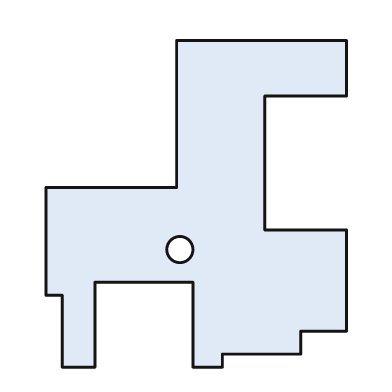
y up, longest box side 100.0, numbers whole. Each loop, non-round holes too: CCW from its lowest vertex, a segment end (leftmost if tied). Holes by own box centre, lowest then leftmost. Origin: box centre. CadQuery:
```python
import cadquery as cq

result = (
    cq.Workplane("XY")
    .moveTo(-41.0, -50.0)
    .lineTo(-31.0, -50.0)
    .lineTo(-31.0, -24.0)
    .lineTo(-1.0, -24.0)
    .lineTo(-1.0, -50.0)
    .lineTo(8.0, -50.0)
    .lineTo(8.0, -46.0)
    .lineTo(32.0, -46.0)
    .lineTo(32.0, -39.0)
    .lineTo(46.0, -39.0)
    .lineTo(46.0, -8.0)
    .lineTo(21.0, -8.0)
    .lineTo(21.0, 33.0)
    .lineTo(46.0, 33.0)
    .lineTo(46.0, 50.0)
    .lineTo(-6.0, 50.0)
    .lineTo(-6.0, 5.0)
    .lineTo(-46.0, 5.0)
    .lineTo(-46.0, -28.0)
    .lineTo(-41.0, -28.0)
    .close()
    .moveTo(-5.0, -14.0)
    .circle(4.0)
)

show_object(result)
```